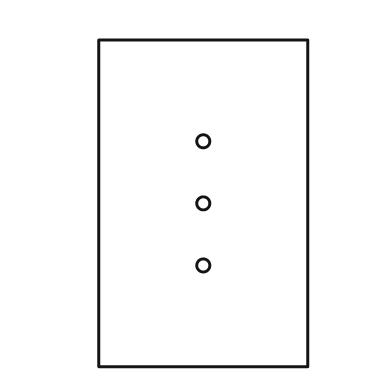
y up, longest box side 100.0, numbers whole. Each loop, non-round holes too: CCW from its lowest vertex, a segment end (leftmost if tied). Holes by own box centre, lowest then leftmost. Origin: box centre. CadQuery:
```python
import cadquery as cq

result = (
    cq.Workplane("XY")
    .moveTo(-32.0, -50.0)
    .lineTo(32.0, -50.0)
    .lineTo(32.0, 50.0)
    .lineTo(-32.0, 50.0)
    .close()
    .moveTo(0.0, -19.0)
    .circle(2.0)
    .moveTo(0.0, 0.0)
    .circle(2.0)
    .moveTo(0.0, 19.0)
    .circle(2.0)
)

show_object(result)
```